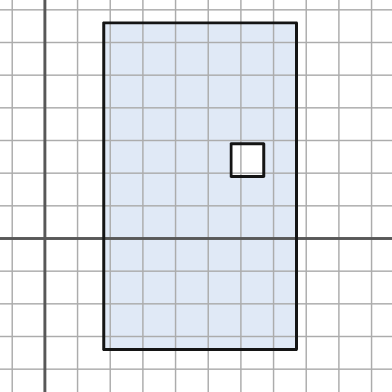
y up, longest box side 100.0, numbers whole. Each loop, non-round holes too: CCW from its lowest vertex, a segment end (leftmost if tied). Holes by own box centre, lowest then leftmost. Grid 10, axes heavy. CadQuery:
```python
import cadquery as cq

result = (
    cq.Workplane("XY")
    .moveTo(18.0, -34.0)
    .lineTo(77.0, -34.0)
    .lineTo(77.0, 66.0)
    .lineTo(18.0, 66.0)
    .close()
    .moveTo(57.0, 19.0)
    .lineTo(67.0, 19.0)
    .lineTo(67.0, 29.0)
    .lineTo(57.0, 29.0)
    .close()
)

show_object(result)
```